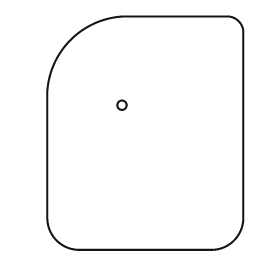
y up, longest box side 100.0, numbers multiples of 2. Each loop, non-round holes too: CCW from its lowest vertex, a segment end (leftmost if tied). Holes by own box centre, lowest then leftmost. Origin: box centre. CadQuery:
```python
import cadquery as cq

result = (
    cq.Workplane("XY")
    .moveTo(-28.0, -50.0)
    .lineTo(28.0, -50.0)
    .threePointArc((38.0, -46.0), (42.0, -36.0))
    .lineTo(42.0, 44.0)
    .threePointArc((40.0, 48.0), (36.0, 50.0))
    .lineTo(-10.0, 50.0)
    .threePointArc((-32.0, 40.0), (-42.0, 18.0))
    .lineTo(-42.0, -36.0)
    .threePointArc((-38.0, -46.0), (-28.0, -50.0))
    .close()
    .moveTo(-10.0, 12.0)
    .circle(2.0)
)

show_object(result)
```